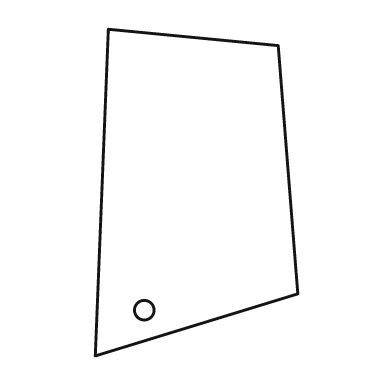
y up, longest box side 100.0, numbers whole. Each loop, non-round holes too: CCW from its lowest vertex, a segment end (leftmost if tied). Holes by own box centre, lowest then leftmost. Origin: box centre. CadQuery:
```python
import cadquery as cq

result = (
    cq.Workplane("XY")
    .moveTo(-31.0, -50.0)
    .lineTo(31.0, -31.0)
    .lineTo(25.0, 45.0)
    .lineTo(-27.0, 50.0)
    .close()
    .moveTo(-16.0, -36.0)
    .circle(3.0)
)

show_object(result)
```